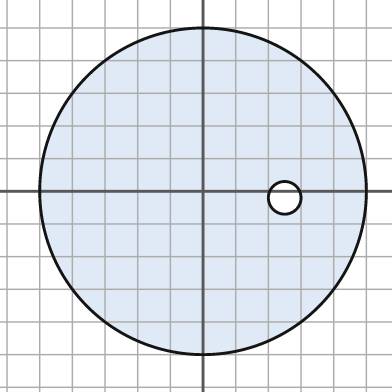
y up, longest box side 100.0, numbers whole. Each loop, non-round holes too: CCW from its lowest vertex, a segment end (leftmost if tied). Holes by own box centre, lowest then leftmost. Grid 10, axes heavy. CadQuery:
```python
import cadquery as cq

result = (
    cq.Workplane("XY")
    .moveTo(0.0, 0.0)
    .circle(50.0)
    .moveTo(25.0, -2.0)
    .circle(5.0)
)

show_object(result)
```